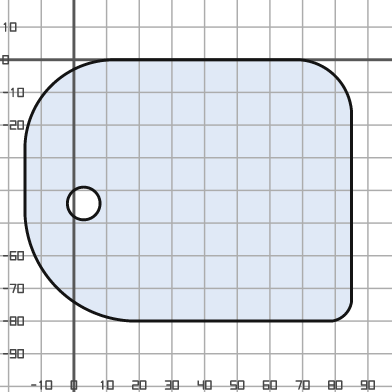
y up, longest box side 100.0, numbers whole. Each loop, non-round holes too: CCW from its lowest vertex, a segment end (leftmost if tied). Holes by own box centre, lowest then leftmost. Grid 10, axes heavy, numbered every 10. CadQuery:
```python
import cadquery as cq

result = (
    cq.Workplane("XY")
    .moveTo(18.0, -80.0)
    .lineTo(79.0, -80.0)
    .threePointArc((83.0, -78.0), (85.0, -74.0))
    .lineTo(85.0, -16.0)
    .threePointArc((80.0, -5.0), (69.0, 0.0))
    .lineTo(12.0, 0.0)
    .threePointArc((-7.0, -8.0), (-15.0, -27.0))
    .lineTo(-15.0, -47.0)
    .threePointArc((-5.0, -70.0), (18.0, -80.0))
    .close()
    .moveTo(3.0, -44.0)
    .circle(5.0)
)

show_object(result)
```